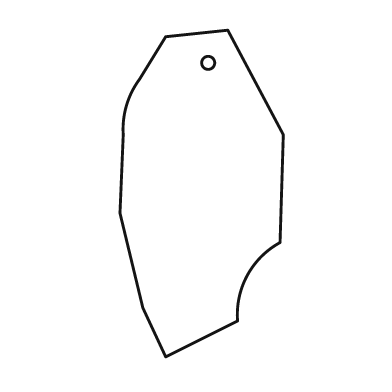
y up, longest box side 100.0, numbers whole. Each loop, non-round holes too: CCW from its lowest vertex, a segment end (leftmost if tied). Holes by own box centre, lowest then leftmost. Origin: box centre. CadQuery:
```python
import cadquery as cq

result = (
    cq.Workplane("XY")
    .moveTo(-11.0, -50.0)
    .lineTo(11.0, -39.0)
    .threePointArc((14.0, -25.0), (24.0, -15.0))
    .lineTo(25.0, 18.0)
    .lineTo(8.0, 50.0)
    .lineTo(-11.0, 48.0)
    .lineTo(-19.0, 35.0)
    .threePointArc((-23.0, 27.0), (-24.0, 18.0))
    .lineTo(-25.0, -6.0)
    .lineTo(-18.0, -35.0)
    .close()
    .moveTo(2.0, 40.0)
    .circle(2.0)
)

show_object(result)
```